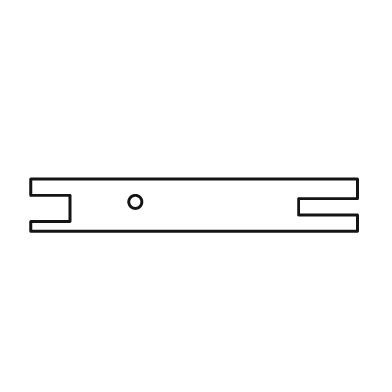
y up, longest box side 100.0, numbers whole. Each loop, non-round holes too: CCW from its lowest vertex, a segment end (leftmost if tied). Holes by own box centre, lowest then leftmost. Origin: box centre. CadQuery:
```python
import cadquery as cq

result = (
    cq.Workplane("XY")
    .moveTo(-50.0, -8.0)
    .lineTo(50.0, -8.0)
    .lineTo(50.0, -3.0)
    .lineTo(32.0, -3.0)
    .lineTo(32.0, 2.0)
    .lineTo(50.0, 2.0)
    .lineTo(50.0, 8.0)
    .lineTo(-50.0, 8.0)
    .lineTo(-50.0, 3.0)
    .lineTo(-38.0, 3.0)
    .lineTo(-38.0, -5.0)
    .lineTo(-50.0, -5.0)
    .close()
    .moveTo(-18.0, 1.0)
    .circle(2.0)
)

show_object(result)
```